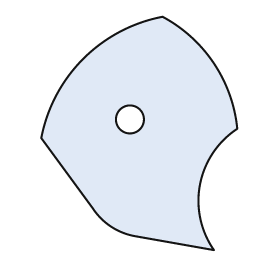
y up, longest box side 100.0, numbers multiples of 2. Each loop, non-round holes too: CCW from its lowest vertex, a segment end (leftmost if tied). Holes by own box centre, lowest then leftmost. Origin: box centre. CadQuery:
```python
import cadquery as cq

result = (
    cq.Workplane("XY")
    .moveTo(32.0, -50.0)
    .threePointArc((26.0, -22.0), (42.0, 2.0))
    .threePointArc((32.0, 30.0), (10.0, 50.0))
    .threePointArc((-24.0, 32.0), (-42.0, -2.0))
    .lineTo(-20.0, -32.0)
    .threePointArc((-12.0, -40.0), (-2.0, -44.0))
    .close()
    .moveTo(-4.0, 6.0)
    .circle(6.0)
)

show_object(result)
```